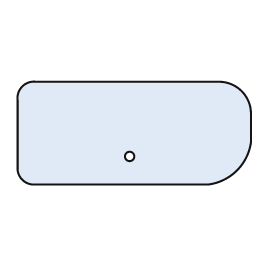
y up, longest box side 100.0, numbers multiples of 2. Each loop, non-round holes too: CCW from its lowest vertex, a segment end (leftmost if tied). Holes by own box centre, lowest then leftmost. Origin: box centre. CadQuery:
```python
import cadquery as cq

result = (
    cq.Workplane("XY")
    .moveTo(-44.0, -22.0)
    .lineTo(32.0, -22.0)
    .threePointArc((44.0, -16.0), (50.0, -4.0))
    .lineTo(50.0, 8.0)
    .threePointArc((46.0, 18.0), (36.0, 22.0))
    .lineTo(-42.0, 22.0)
    .threePointArc((-48.0, 20.0), (-50.0, 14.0))
    .lineTo(-50.0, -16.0)
    .threePointArc((-48.0, -20.0), (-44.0, -22.0))
    .close()
    .moveTo(-2.0, -10.0)
    .circle(2.0)
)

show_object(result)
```